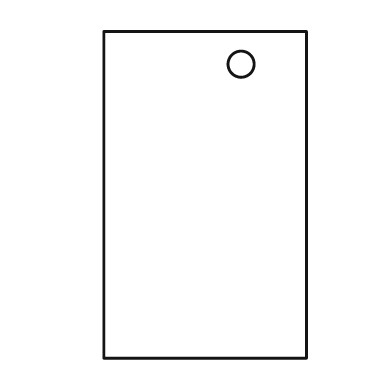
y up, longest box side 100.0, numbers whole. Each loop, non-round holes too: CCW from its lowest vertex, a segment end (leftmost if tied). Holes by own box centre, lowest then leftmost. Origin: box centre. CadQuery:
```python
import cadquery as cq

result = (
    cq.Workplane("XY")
    .moveTo(-31.0, -50.0)
    .lineTo(31.0, -50.0)
    .lineTo(31.0, 50.0)
    .lineTo(-31.0, 50.0)
    .close()
    .moveTo(11.0, 40.0)
    .circle(4.0)
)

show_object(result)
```